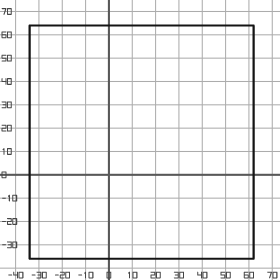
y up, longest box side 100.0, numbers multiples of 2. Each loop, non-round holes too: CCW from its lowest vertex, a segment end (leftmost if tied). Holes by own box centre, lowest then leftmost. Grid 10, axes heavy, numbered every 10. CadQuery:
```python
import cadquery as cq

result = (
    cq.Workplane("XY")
    .moveTo(-34.0, -36.0)
    .lineTo(62.0, -36.0)
    .lineTo(62.0, 64.0)
    .lineTo(-34.0, 64.0)
    .close()
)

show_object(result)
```